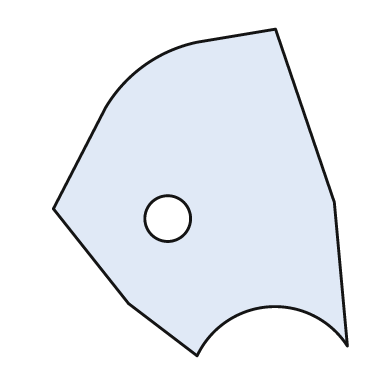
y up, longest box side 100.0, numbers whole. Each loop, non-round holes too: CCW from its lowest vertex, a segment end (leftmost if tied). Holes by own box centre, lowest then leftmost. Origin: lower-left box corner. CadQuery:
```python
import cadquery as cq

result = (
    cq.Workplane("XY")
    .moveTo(44.0, 0.0)
    .threePointArc((66.0, 15.0), (90.0, 3.0))
    .lineTo(86.0, 47.0)
    .lineTo(68.0, 100.0)
    .lineTo(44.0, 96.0)
    .threePointArc((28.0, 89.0), (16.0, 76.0))
    .lineTo(0.0, 45.0)
    .lineTo(23.0, 16.0)
    .close()
    .moveTo(35.0, 42.0)
    .circle(7.0)
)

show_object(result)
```